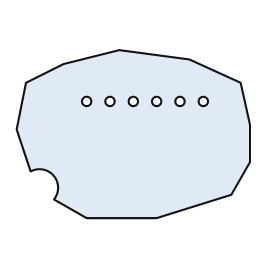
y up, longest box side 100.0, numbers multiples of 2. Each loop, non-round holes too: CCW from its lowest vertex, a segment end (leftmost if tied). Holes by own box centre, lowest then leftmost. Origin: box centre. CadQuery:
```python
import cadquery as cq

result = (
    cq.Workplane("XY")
    .moveTo(-20.0, -36.0)
    .lineTo(10.0, -36.0)
    .lineTo(42.0, -26.0)
    .lineTo(50.0, -12.0)
    .lineTo(50.0, 4.0)
    .lineTo(46.0, 22.0)
    .lineTo(24.0, 32.0)
    .lineTo(-6.0, 36.0)
    .lineTo(-30.0, 30.0)
    .lineTo(-46.0, 22.0)
    .lineTo(-50.0, 2.0)
    .lineTo(-44.0, -16.0)
    .threePointArc((-34.0, -18.0), (-34.0, -28.0))
    .close()
    .moveTo(-20.0, 14.0)
    .circle(2.0)
    .moveTo(-10.0, 14.0)
    .circle(2.0)
    .moveTo(0.0, 14.0)
    .circle(2.0)
    .moveTo(10.0, 14.0)
    .circle(2.0)
    .moveTo(20.0, 14.0)
    .circle(2.0)
    .moveTo(30.0, 14.0)
    .circle(2.0)
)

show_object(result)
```